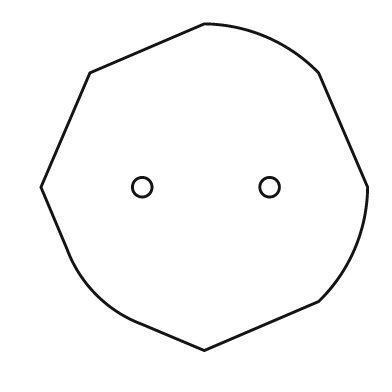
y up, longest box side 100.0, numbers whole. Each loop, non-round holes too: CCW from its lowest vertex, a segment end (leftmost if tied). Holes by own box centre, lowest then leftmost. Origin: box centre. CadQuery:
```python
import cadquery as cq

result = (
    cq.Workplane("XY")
    .moveTo(0.0, -50.0)
    .lineTo(35.0, -35.0)
    .threePointArc((46.0, -19.0), (50.0, 0.0))
    .lineTo(35.0, 35.0)
    .threePointArc((19.0, 46.0), (0.0, 50.0))
    .lineTo(-35.0, 35.0)
    .lineTo(-50.0, 0.0)
    .lineTo(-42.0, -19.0)
    .threePointArc((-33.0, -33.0), (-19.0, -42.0))
    .close()
    .moveTo(-19.0, 0.0)
    .circle(3.0)
    .moveTo(20.0, 0.0)
    .circle(3.0)
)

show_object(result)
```